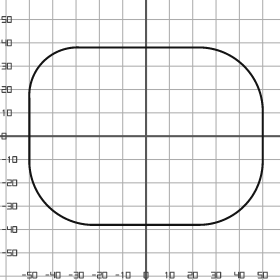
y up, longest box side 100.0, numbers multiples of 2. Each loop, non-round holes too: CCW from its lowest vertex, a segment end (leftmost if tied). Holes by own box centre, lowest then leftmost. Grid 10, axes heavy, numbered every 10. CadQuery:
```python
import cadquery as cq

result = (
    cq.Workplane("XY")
    .moveTo(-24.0, -38.0)
    .lineTo(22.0, -38.0)
    .threePointArc((42.0, -30.0), (50.0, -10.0))
    .lineTo(50.0, 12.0)
    .threePointArc((42.0, 30.0), (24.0, 38.0))
    .lineTo(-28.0, 38.0)
    .threePointArc((-44.0, 32.0), (-50.0, 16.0))
    .lineTo(-50.0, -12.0)
    .threePointArc((-42.0, -30.0), (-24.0, -38.0))
    .close()
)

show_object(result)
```